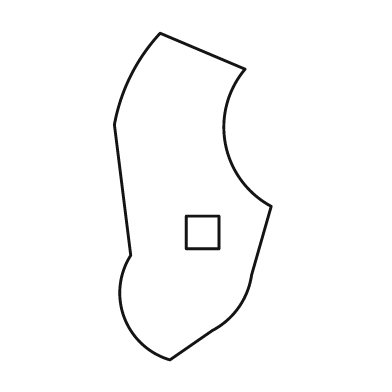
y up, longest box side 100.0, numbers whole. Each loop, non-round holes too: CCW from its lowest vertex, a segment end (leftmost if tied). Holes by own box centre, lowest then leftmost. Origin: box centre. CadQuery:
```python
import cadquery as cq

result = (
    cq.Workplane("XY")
    .moveTo(-7.0, -50.0)
    .lineTo(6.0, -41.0)
    .threePointArc((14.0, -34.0), (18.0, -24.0))
    .lineTo(24.0, -3.0)
    .threePointArc((10.0, 16.0), (16.0, 39.0))
    .lineTo(-10.0, 50.0)
    .threePointArc((-19.0, 37.0), (-24.0, 22.0))
    .lineTo(-19.0, -18.0)
    .threePointArc((-21.0, -37.0), (-7.0, -50.0))
    .close()
    .moveTo(-2.0, -16.0)
    .lineTo(8.0, -16.0)
    .lineTo(8.0, -6.0)
    .lineTo(-2.0, -6.0)
    .close()
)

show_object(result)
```